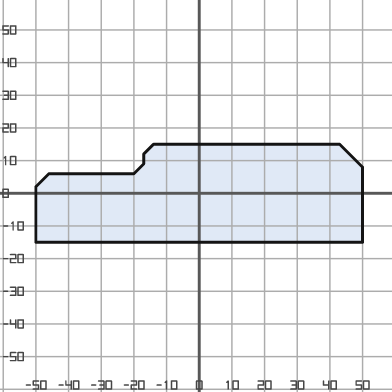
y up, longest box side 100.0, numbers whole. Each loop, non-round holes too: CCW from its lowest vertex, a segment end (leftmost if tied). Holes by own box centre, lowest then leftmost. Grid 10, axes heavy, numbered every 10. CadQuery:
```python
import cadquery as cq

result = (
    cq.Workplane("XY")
    .moveTo(-50.0, -15.0)
    .lineTo(50.0, -15.0)
    .lineTo(50.0, 8.0)
    .lineTo(43.0, 15.0)
    .lineTo(-14.0, 15.0)
    .lineTo(-17.0, 12.0)
    .lineTo(-17.0, 9.0)
    .lineTo(-20.0, 6.0)
    .lineTo(-46.0, 6.0)
    .lineTo(-50.0, 2.0)
    .close()
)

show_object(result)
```